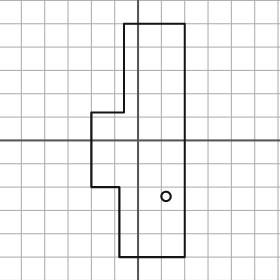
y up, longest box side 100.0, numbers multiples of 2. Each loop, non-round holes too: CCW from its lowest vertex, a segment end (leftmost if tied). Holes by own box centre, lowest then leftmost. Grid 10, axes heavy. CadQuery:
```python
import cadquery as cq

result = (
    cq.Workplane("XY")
    .moveTo(-8.0, -50.0)
    .lineTo(20.0, -50.0)
    .lineTo(20.0, 50.0)
    .lineTo(-6.0, 50.0)
    .lineTo(-6.0, 12.0)
    .lineTo(-20.0, 12.0)
    .lineTo(-20.0, -20.0)
    .lineTo(-8.0, -20.0)
    .close()
    .moveTo(12.0, -24.0)
    .circle(2.0)
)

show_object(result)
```